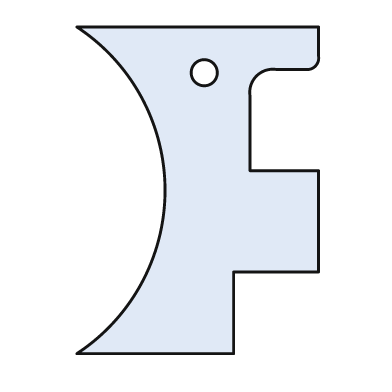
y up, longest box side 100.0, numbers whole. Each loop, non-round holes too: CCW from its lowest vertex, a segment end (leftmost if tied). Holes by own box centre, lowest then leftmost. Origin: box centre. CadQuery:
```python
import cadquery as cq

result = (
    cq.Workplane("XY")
    .moveTo(-37.0, -50.0)
    .lineTo(11.0, -50.0)
    .lineTo(11.0, -25.0)
    .lineTo(37.0, -25.0)
    .lineTo(37.0, 6.0)
    .lineTo(16.0, 6.0)
    .lineTo(16.0, 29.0)
    .threePointArc((18.0, 35.0), (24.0, 37.0))
    .lineTo(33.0, 37.0)
    .threePointArc((36.0, 38.0), (37.0, 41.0))
    .lineTo(37.0, 50.0)
    .lineTo(-37.0, 50.0)
    .threePointArc((-10.0, 0.0), (-37.0, -50.0))
    .close()
    .moveTo(2.0, 36.0)
    .circle(4.0)
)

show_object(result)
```